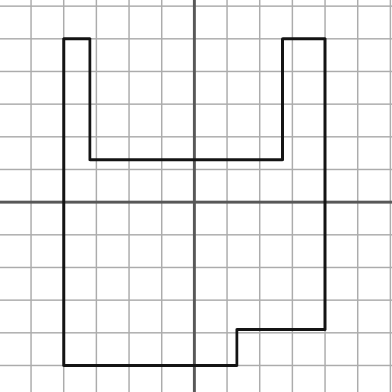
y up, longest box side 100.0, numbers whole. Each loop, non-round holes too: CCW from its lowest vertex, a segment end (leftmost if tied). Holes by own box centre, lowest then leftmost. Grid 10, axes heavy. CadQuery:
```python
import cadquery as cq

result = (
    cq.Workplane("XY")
    .moveTo(-40.0, -50.0)
    .lineTo(13.0, -50.0)
    .lineTo(13.0, -39.0)
    .lineTo(40.0, -39.0)
    .lineTo(40.0, 50.0)
    .lineTo(27.0, 50.0)
    .lineTo(27.0, 13.0)
    .lineTo(-32.0, 13.0)
    .lineTo(-32.0, 50.0)
    .lineTo(-40.0, 50.0)
    .close()
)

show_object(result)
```